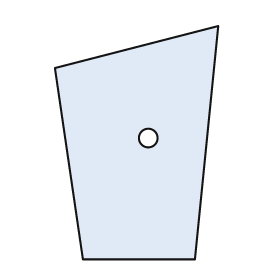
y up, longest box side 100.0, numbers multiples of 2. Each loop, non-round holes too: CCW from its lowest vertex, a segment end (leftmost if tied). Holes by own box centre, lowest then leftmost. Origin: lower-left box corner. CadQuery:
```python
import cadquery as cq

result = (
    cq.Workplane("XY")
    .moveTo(12.0, 0.0)
    .lineTo(60.0, 0.0)
    .lineTo(70.0, 100.0)
    .lineTo(0.0, 82.0)
    .close()
    .moveTo(40.0, 52.0)
    .circle(4.0)
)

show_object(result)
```